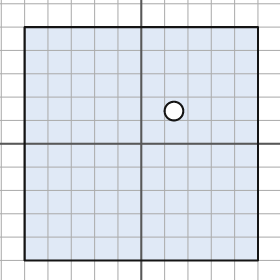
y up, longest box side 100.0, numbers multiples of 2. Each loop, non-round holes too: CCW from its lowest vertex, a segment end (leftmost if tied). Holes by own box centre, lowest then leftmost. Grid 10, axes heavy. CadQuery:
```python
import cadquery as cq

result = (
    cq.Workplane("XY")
    .moveTo(-50.0, -50.0)
    .lineTo(50.0, -50.0)
    .lineTo(50.0, 50.0)
    .lineTo(-50.0, 50.0)
    .close()
    .moveTo(14.0, 14.0)
    .circle(4.0)
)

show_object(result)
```